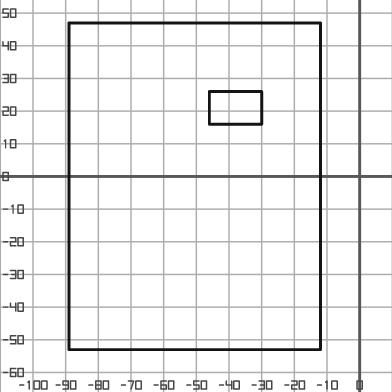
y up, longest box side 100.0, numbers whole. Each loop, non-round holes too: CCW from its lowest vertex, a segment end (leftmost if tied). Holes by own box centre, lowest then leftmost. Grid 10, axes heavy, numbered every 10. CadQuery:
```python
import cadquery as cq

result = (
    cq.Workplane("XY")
    .moveTo(-89.0, -53.0)
    .lineTo(-12.0, -53.0)
    .lineTo(-12.0, 47.0)
    .lineTo(-89.0, 47.0)
    .close()
    .moveTo(-46.0, 16.0)
    .lineTo(-30.0, 16.0)
    .lineTo(-30.0, 26.0)
    .lineTo(-46.0, 26.0)
    .close()
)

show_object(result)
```